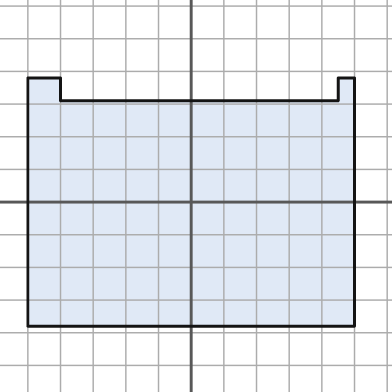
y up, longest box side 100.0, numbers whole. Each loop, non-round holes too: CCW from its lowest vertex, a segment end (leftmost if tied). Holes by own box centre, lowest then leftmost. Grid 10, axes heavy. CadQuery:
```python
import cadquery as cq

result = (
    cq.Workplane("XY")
    .moveTo(-50.0, -38.0)
    .lineTo(50.0, -38.0)
    .lineTo(50.0, 38.0)
    .lineTo(45.0, 38.0)
    .lineTo(45.0, 31.0)
    .lineTo(-40.0, 31.0)
    .lineTo(-40.0, 38.0)
    .lineTo(-50.0, 38.0)
    .close()
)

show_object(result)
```